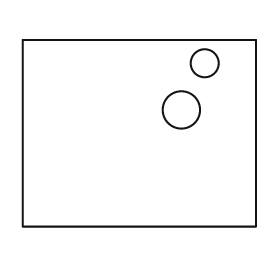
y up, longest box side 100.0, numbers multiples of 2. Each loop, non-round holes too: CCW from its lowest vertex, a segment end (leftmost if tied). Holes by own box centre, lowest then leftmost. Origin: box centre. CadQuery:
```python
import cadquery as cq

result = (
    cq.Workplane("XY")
    .moveTo(-50.0, -40.0)
    .lineTo(50.0, -40.0)
    .lineTo(50.0, 40.0)
    .lineTo(-50.0, 40.0)
    .close()
    .moveTo(18.0, 10.0)
    .circle(8.0)
    .moveTo(28.0, 30.0)
    .circle(6.0)
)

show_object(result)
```